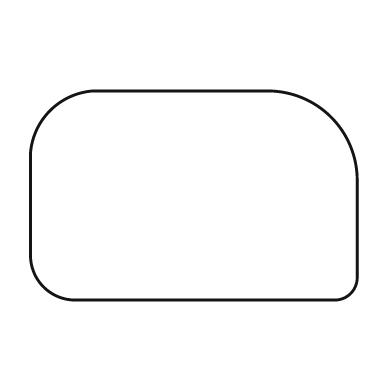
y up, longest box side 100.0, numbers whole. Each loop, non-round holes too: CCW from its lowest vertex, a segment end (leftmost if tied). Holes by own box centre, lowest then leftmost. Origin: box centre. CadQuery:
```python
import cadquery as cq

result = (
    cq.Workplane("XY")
    .moveTo(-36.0, -32.0)
    .lineTo(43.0, -32.0)
    .threePointArc((48.0, -30.0), (50.0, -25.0))
    .lineTo(50.0, 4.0)
    .threePointArc((42.0, 24.0), (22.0, 32.0))
    .lineTo(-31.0, 32.0)
    .threePointArc((-44.0, 26.0), (-50.0, 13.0))
    .lineTo(-50.0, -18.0)
    .threePointArc((-46.0, -28.0), (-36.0, -32.0))
    .close()
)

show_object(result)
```